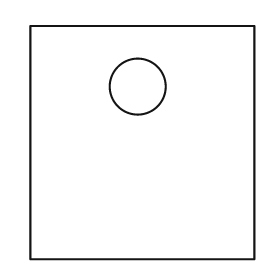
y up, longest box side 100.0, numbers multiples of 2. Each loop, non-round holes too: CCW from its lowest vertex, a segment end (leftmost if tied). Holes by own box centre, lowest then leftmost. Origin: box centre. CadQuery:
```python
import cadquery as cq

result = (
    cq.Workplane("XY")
    .moveTo(-48.0, -50.0)
    .lineTo(48.0, -50.0)
    .lineTo(48.0, 50.0)
    .lineTo(-48.0, 50.0)
    .close()
    .moveTo(-2.0, 24.0)
    .circle(12.0)
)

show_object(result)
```